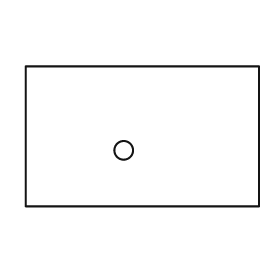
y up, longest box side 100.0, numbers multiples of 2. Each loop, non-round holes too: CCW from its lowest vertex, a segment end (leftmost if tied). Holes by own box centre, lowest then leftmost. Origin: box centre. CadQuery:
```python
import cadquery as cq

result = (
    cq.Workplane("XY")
    .moveTo(-50.0, -30.0)
    .lineTo(50.0, -30.0)
    .lineTo(50.0, 30.0)
    .lineTo(-50.0, 30.0)
    .close()
    .moveTo(-8.0, -6.0)
    .circle(4.0)
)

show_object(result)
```